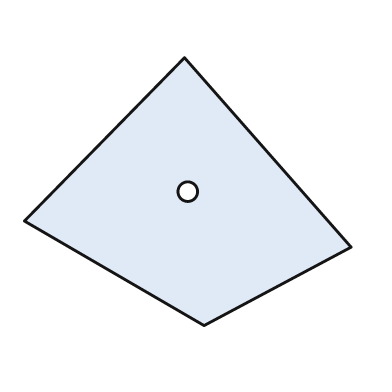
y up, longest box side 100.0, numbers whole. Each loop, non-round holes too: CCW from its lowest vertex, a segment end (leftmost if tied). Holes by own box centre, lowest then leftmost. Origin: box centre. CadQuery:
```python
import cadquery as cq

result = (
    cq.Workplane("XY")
    .moveTo(5.0, -41.0)
    .lineTo(50.0, -17.0)
    .lineTo(-1.0, 41.0)
    .lineTo(-50.0, -9.0)
    .close()
    .moveTo(0.0, 0.0)
    .circle(3.0)
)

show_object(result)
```